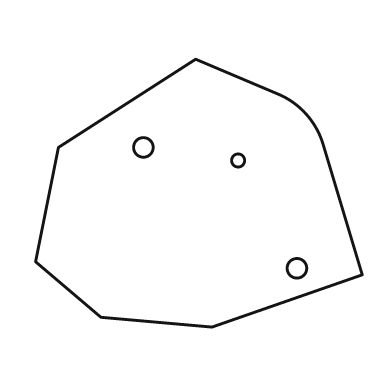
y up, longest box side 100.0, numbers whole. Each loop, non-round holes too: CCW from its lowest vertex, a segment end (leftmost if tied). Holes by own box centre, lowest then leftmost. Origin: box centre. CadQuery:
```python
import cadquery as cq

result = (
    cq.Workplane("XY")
    .moveTo(4.0, -41.0)
    .lineTo(50.0, -25.0)
    .lineTo(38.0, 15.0)
    .threePointArc((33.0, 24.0), (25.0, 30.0))
    .lineTo(-1.0, 41.0)
    .lineTo(-43.0, 14.0)
    .lineTo(-50.0, -21.0)
    .lineTo(-30.0, -38.0)
    .close()
    .moveTo(30.0, -23.0)
    .circle(3.0)
    .moveTo(12.0, 10.0)
    .circle(2.0)
    .moveTo(-17.0, 14.0)
    .circle(3.0)
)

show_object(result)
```